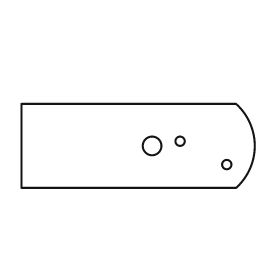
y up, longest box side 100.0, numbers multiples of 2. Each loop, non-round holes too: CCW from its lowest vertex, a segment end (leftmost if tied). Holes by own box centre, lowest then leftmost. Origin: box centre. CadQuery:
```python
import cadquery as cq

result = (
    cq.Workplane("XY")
    .moveTo(-50.0, -18.0)
    .lineTo(42.0, -18.0)
    .threePointArc((50.0, 0.0), (42.0, 18.0))
    .lineTo(-50.0, 18.0)
    .close()
    .moveTo(38.0, -8.0)
    .circle(2.0)
    .moveTo(6.0, 0.0)
    .circle(4.0)
    .moveTo(18.0, 2.0)
    .circle(2.0)
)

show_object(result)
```